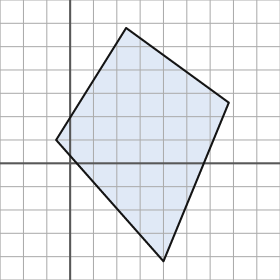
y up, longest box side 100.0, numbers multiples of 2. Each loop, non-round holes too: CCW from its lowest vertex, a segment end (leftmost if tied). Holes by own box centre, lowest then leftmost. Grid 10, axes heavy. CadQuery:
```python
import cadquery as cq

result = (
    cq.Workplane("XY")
    .moveTo(40.0, -42.0)
    .lineTo(68.0, 26.0)
    .lineTo(24.0, 58.0)
    .lineTo(-6.0, 10.0)
    .close()
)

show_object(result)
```